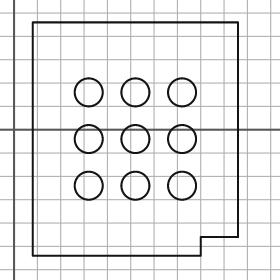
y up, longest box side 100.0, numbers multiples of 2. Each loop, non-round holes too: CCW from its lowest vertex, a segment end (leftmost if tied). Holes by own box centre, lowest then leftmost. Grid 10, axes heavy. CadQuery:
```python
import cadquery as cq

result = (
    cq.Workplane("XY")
    .moveTo(8.0, -54.0)
    .lineTo(80.0, -54.0)
    .lineTo(80.0, -46.0)
    .lineTo(96.0, -46.0)
    .lineTo(96.0, 46.0)
    .lineTo(8.0, 46.0)
    .close()
    .moveTo(32.0, -24.0)
    .circle(6.0)
    .moveTo(52.0, -24.0)
    .circle(6.0)
    .moveTo(72.0, -24.0)
    .circle(6.0)
    .moveTo(32.0, -4.0)
    .circle(6.0)
    .moveTo(52.0, -4.0)
    .circle(6.0)
    .moveTo(72.0, -4.0)
    .circle(6.0)
    .moveTo(32.0, 16.0)
    .circle(6.0)
    .moveTo(52.0, 16.0)
    .circle(6.0)
    .moveTo(72.0, 16.0)
    .circle(6.0)
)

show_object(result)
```